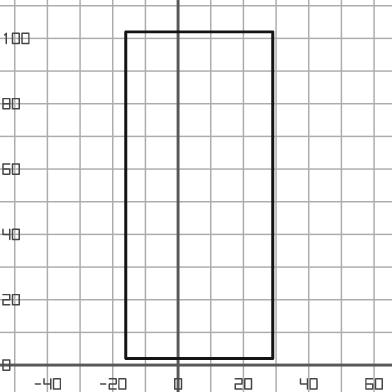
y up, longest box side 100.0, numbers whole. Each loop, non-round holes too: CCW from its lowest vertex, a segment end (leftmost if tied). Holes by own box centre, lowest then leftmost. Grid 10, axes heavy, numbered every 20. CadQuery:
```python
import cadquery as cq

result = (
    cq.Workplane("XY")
    .moveTo(-16.0, 2.0)
    .lineTo(29.0, 2.0)
    .lineTo(29.0, 102.0)
    .lineTo(-16.0, 102.0)
    .close()
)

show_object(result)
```